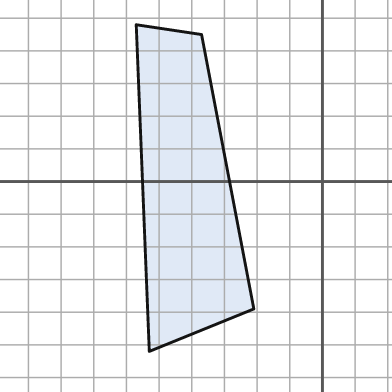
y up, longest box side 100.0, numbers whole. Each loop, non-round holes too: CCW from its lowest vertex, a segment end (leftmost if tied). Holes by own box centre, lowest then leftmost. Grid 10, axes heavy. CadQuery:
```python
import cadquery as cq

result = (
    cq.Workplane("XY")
    .moveTo(-53.0, -52.0)
    .lineTo(-21.0, -39.0)
    .lineTo(-37.0, 45.0)
    .lineTo(-57.0, 48.0)
    .close()
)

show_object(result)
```